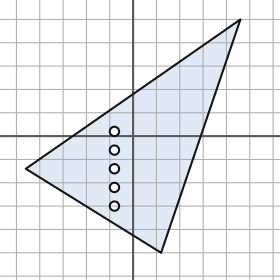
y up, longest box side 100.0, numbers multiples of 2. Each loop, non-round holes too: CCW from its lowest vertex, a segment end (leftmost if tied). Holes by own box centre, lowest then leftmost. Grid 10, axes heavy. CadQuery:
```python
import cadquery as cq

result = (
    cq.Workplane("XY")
    .moveTo(12.0, -50.0)
    .lineTo(46.0, 50.0)
    .lineTo(-46.0, -14.0)
    .close()
    .moveTo(-8.0, -30.0)
    .circle(2.0)
    .moveTo(-8.0, -22.0)
    .circle(2.0)
    .moveTo(-8.0, -14.0)
    .circle(2.0)
    .moveTo(-8.0, -6.0)
    .circle(2.0)
    .moveTo(-8.0, 2.0)
    .circle(2.0)
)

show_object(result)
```